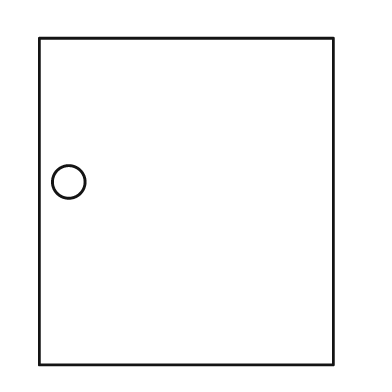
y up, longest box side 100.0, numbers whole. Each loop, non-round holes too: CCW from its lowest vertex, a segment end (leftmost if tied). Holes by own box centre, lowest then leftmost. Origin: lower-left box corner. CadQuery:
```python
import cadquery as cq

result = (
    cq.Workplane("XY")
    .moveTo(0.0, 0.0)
    .lineTo(90.0, 0.0)
    .lineTo(90.0, 100.0)
    .lineTo(0.0, 100.0)
    .close()
    .moveTo(9.0, 56.0)
    .circle(5.0)
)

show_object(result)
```